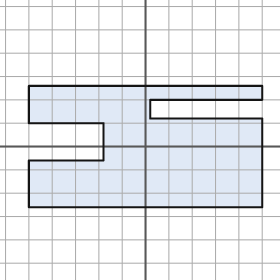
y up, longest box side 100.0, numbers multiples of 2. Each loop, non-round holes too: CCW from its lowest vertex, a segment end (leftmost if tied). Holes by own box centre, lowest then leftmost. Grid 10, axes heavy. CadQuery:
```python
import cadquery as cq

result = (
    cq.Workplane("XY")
    .moveTo(-50.0, -26.0)
    .lineTo(50.0, -26.0)
    .lineTo(50.0, 12.0)
    .lineTo(2.0, 12.0)
    .lineTo(2.0, 20.0)
    .lineTo(50.0, 20.0)
    .lineTo(50.0, 26.0)
    .lineTo(-50.0, 26.0)
    .lineTo(-50.0, 10.0)
    .lineTo(-18.0, 10.0)
    .lineTo(-18.0, -6.0)
    .lineTo(-50.0, -6.0)
    .close()
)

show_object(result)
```